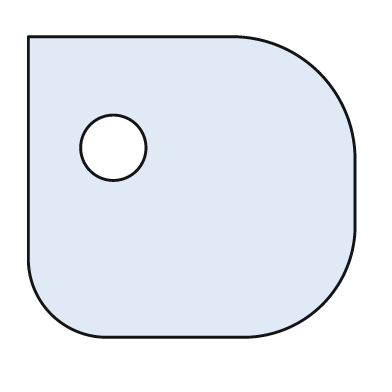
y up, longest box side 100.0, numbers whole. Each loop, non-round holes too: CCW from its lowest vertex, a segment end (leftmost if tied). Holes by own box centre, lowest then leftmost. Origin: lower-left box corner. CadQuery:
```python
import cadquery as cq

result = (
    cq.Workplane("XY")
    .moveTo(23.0, 0.0)
    .lineTo(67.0, 0.0)
    .threePointArc((90.0, 10.0), (100.0, 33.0))
    .lineTo(100.0, 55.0)
    .threePointArc((89.0, 81.0), (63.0, 92.0))
    .lineTo(0.0, 92.0)
    .lineTo(0.0, 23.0)
    .threePointArc((7.0, 7.0), (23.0, 0.0))
    .close()
    .moveTo(26.0, 58.0)
    .circle(10.0)
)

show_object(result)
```